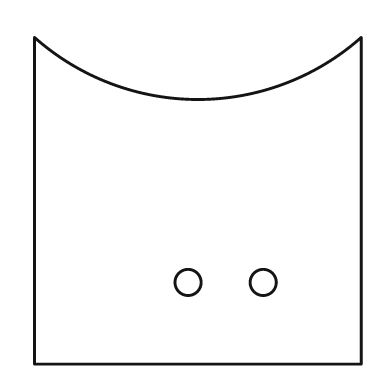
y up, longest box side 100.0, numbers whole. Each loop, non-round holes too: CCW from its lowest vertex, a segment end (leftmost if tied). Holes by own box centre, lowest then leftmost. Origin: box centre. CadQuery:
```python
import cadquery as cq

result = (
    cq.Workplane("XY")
    .moveTo(-50.0, -50.0)
    .lineTo(50.0, -50.0)
    .lineTo(50.0, 50.0)
    .threePointArc((0.0, 31.0), (-50.0, 50.0))
    .close()
    .moveTo(-3.0, -25.0)
    .circle(4.0)
    .moveTo(20.0, -25.0)
    .circle(4.0)
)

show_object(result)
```